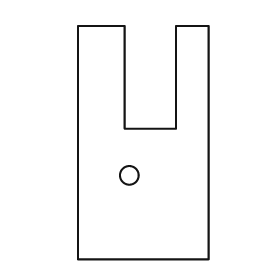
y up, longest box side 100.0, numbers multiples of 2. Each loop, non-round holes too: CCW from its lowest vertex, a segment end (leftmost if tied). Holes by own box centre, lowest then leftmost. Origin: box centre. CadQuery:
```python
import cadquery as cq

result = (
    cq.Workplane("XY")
    .moveTo(-28.0, -50.0)
    .lineTo(28.0, -50.0)
    .lineTo(28.0, 50.0)
    .lineTo(14.0, 50.0)
    .lineTo(14.0, 6.0)
    .lineTo(-8.0, 6.0)
    .lineTo(-8.0, 50.0)
    .lineTo(-28.0, 50.0)
    .close()
    .moveTo(-6.0, -14.0)
    .circle(4.0)
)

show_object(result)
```